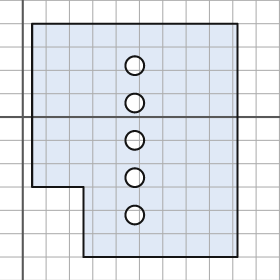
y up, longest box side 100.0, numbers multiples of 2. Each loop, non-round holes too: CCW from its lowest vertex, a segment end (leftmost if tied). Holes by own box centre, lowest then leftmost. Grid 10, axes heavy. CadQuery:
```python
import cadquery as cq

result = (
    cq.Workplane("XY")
    .moveTo(26.0, -60.0)
    .lineTo(92.0, -60.0)
    .lineTo(92.0, 40.0)
    .lineTo(4.0, 40.0)
    .lineTo(4.0, -30.0)
    .lineTo(26.0, -30.0)
    .close()
    .moveTo(48.0, -42.0)
    .circle(4.0)
    .moveTo(48.0, -26.0)
    .circle(4.0)
    .moveTo(48.0, -10.0)
    .circle(4.0)
    .moveTo(48.0, 6.0)
    .circle(4.0)
    .moveTo(48.0, 22.0)
    .circle(4.0)
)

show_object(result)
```